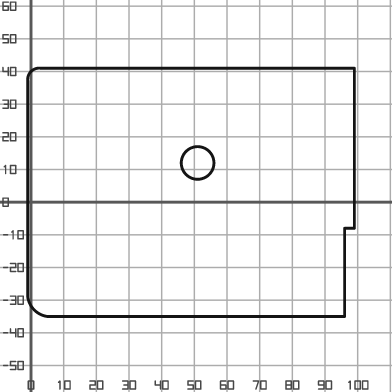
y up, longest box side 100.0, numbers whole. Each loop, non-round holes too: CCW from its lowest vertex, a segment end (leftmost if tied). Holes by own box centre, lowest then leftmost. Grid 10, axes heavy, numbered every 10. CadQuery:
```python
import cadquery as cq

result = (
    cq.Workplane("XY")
    .moveTo(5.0, -35.0)
    .lineTo(96.0, -35.0)
    .lineTo(96.0, -8.0)
    .lineTo(99.0, -8.0)
    .lineTo(99.0, 41.0)
    .lineTo(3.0, 41.0)
    .threePointArc((0.0, 40.0), (-1.0, 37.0))
    .lineTo(-1.0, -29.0)
    .threePointArc((1.0, -33.0), (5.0, -35.0))
    .close()
    .moveTo(51.0, 12.0)
    .circle(5.0)
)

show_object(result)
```